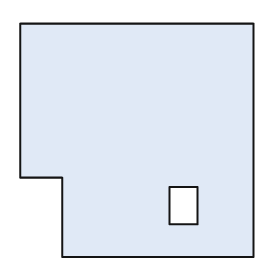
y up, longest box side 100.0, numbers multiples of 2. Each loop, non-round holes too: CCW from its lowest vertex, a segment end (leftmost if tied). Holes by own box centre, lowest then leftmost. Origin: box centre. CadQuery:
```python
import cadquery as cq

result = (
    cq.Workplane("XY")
    .moveTo(-32.0, -50.0)
    .lineTo(50.0, -50.0)
    .lineTo(50.0, 50.0)
    .lineTo(-50.0, 50.0)
    .lineTo(-50.0, -16.0)
    .lineTo(-32.0, -16.0)
    .close()
    .moveTo(14.0, -36.0)
    .lineTo(26.0, -36.0)
    .lineTo(26.0, -20.0)
    .lineTo(14.0, -20.0)
    .close()
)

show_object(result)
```